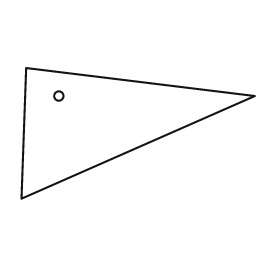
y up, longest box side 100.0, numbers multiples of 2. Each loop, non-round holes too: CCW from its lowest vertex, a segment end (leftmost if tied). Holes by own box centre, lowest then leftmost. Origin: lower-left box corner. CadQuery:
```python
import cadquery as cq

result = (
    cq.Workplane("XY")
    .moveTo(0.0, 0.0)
    .lineTo(100.0, 44.0)
    .lineTo(2.0, 56.0)
    .close()
    .moveTo(16.0, 44.0)
    .circle(2.0)
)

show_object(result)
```